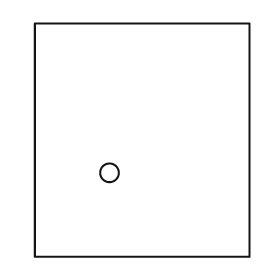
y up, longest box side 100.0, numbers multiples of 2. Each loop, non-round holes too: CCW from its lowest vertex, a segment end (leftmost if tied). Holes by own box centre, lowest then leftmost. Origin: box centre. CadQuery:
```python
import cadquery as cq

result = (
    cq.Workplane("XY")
    .moveTo(-46.0, -50.0)
    .lineTo(46.0, -50.0)
    .lineTo(46.0, 50.0)
    .lineTo(-46.0, 50.0)
    .close()
    .moveTo(-14.0, -14.0)
    .circle(4.0)
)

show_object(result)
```